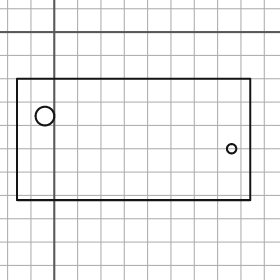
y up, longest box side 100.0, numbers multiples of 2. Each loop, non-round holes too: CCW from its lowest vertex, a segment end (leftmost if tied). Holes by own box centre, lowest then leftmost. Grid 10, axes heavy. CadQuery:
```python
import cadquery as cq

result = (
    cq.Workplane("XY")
    .moveTo(-16.0, -72.0)
    .lineTo(84.0, -72.0)
    .lineTo(84.0, -20.0)
    .lineTo(-16.0, -20.0)
    .close()
    .moveTo(76.0, -50.0)
    .circle(2.0)
    .moveTo(-4.0, -36.0)
    .circle(4.0)
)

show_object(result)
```